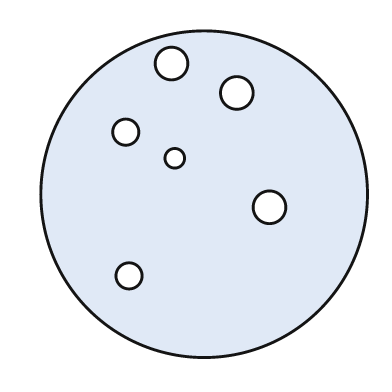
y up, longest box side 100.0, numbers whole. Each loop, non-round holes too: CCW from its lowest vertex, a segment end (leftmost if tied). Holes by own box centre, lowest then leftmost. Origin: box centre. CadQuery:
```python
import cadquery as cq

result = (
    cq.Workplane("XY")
    .moveTo(0.0, 0.0)
    .circle(50.0)
    .moveTo(-23.0, -25.0)
    .circle(4.0)
    .moveTo(20.0, -4.0)
    .circle(5.0)
    .moveTo(-9.0, 11.0)
    .circle(3.0)
    .moveTo(-24.0, 19.0)
    .circle(4.0)
    .moveTo(10.0, 31.0)
    .circle(5.0)
    .moveTo(-10.0, 40.0)
    .circle(5.0)
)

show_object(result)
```